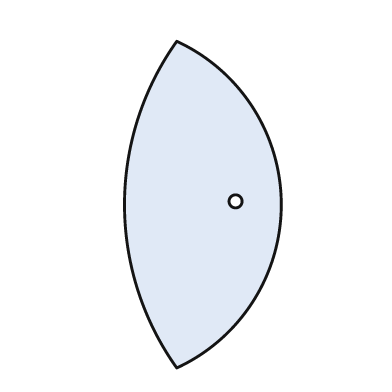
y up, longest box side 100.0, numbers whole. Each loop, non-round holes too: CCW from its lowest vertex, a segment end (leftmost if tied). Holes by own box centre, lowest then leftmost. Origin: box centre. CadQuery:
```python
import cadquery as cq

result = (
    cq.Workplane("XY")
    .moveTo(-8.0, -50.0)
    .threePointArc((24.0, 0.0), (-8.0, 50.0))
    .threePointArc((-24.0, 0.0), (-8.0, -50.0))
    .close()
    .moveTo(10.0, 1.0)
    .circle(2.0)
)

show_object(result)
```